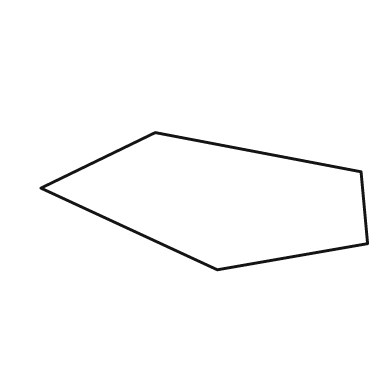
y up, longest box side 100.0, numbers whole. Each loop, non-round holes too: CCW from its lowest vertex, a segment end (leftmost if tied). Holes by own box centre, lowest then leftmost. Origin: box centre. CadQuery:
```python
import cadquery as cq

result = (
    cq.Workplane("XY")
    .moveTo(4.0, -21.0)
    .lineTo(50.0, -13.0)
    .lineTo(48.0, 9.0)
    .lineTo(-15.0, 21.0)
    .lineTo(-50.0, 4.0)
    .close()
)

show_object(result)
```